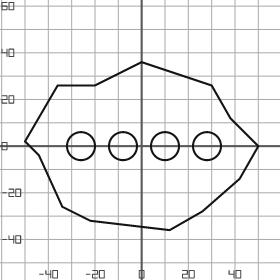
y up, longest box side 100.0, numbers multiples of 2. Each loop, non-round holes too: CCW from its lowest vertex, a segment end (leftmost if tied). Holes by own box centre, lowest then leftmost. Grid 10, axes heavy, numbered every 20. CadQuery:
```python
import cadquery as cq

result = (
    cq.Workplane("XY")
    .moveTo(12.0, -36.0)
    .lineTo(26.0, -28.0)
    .lineTo(42.0, -14.0)
    .lineTo(50.0, 0.0)
    .lineTo(38.0, 12.0)
    .lineTo(30.0, 26.0)
    .lineTo(0.0, 36.0)
    .lineTo(-20.0, 26.0)
    .lineTo(-36.0, 26.0)
    .lineTo(-50.0, 2.0)
    .lineTo(-44.0, -4.0)
    .lineTo(-34.0, -26.0)
    .lineTo(-22.0, -32.0)
    .close()
    .moveTo(-26.0, 0.0)
    .circle(6.0)
    .moveTo(-8.0, 0.0)
    .circle(6.0)
    .moveTo(10.0, 0.0)
    .circle(6.0)
    .moveTo(28.0, 0.0)
    .circle(6.0)
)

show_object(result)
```